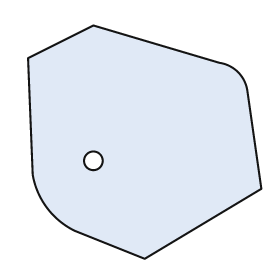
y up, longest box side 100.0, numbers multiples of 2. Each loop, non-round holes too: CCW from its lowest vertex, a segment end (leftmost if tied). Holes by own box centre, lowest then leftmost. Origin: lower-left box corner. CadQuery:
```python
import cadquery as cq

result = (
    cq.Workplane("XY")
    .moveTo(50.0, 0.0)
    .lineTo(100.0, 30.0)
    .lineTo(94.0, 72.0)
    .threePointArc((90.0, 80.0), (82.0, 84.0))
    .lineTo(28.0, 100.0)
    .lineTo(0.0, 86.0)
    .lineTo(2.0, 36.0)
    .threePointArc((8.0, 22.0), (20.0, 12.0))
    .close()
    .moveTo(28.0, 42.0)
    .circle(4.0)
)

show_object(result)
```